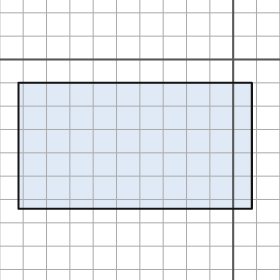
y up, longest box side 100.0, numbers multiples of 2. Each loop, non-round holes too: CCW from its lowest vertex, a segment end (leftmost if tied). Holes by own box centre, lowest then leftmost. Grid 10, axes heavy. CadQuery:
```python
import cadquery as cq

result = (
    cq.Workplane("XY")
    .moveTo(-92.0, -64.0)
    .lineTo(8.0, -64.0)
    .lineTo(8.0, -10.0)
    .lineTo(-92.0, -10.0)
    .close()
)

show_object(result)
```